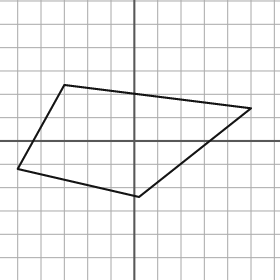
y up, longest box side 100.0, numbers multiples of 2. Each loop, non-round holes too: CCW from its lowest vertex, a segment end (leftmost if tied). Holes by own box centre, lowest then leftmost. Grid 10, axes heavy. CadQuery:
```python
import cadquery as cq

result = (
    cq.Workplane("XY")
    .moveTo(2.0, -24.0)
    .lineTo(50.0, 14.0)
    .lineTo(-30.0, 24.0)
    .lineTo(-50.0, -12.0)
    .close()
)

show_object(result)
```